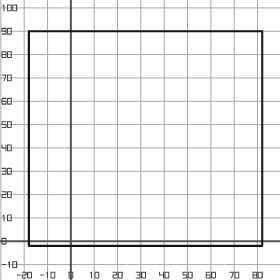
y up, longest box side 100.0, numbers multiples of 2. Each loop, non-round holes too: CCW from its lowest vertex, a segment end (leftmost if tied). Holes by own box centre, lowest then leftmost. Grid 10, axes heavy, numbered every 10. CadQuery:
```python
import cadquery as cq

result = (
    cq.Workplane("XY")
    .moveTo(-18.0, -2.0)
    .lineTo(82.0, -2.0)
    .lineTo(82.0, 90.0)
    .lineTo(-18.0, 90.0)
    .close()
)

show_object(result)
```